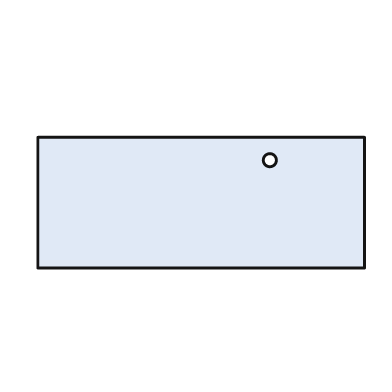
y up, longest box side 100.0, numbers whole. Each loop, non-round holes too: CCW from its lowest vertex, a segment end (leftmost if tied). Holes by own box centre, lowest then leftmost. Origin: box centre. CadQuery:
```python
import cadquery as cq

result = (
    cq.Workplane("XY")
    .moveTo(-50.0, -20.0)
    .lineTo(50.0, -20.0)
    .lineTo(50.0, 20.0)
    .lineTo(-50.0, 20.0)
    .close()
    .moveTo(21.0, 13.0)
    .circle(2.0)
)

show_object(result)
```